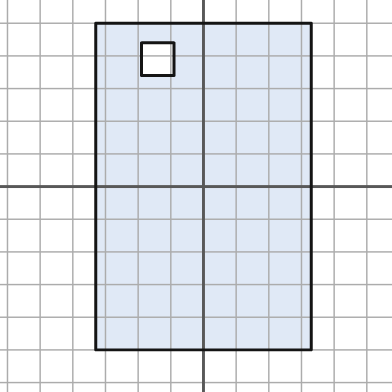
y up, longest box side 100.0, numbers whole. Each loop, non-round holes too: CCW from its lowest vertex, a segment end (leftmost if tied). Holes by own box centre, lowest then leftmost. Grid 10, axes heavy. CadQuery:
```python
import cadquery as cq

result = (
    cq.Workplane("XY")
    .moveTo(-33.0, -50.0)
    .lineTo(33.0, -50.0)
    .lineTo(33.0, 50.0)
    .lineTo(-33.0, 50.0)
    .close()
    .moveTo(-19.0, 34.0)
    .lineTo(-9.0, 34.0)
    .lineTo(-9.0, 44.0)
    .lineTo(-19.0, 44.0)
    .close()
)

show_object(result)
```